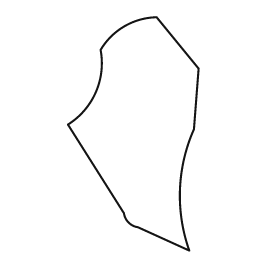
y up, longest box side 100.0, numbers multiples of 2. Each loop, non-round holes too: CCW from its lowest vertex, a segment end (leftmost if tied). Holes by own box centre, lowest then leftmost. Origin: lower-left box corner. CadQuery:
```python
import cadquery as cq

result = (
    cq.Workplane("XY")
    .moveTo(52.0, 0.0)
    .threePointArc((48.0, 26.0), (54.0, 52.0))
    .lineTo(56.0, 78.0)
    .lineTo(38.0, 100.0)
    .threePointArc((24.0, 96.0), (14.0, 86.0))
    .threePointArc((12.0, 68.0), (0.0, 54.0))
    .lineTo(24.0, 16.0)
    .threePointArc((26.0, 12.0), (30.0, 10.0))
    .close()
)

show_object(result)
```